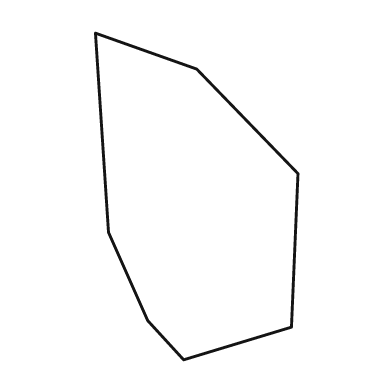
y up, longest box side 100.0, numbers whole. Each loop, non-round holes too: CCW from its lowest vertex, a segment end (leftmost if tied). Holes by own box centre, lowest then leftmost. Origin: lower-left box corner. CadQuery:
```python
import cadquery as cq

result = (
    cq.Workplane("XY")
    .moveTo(27.0, 0.0)
    .lineTo(60.0, 10.0)
    .lineTo(62.0, 57.0)
    .lineTo(31.0, 89.0)
    .lineTo(0.0, 100.0)
    .lineTo(4.0, 39.0)
    .lineTo(16.0, 12.0)
    .close()
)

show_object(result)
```